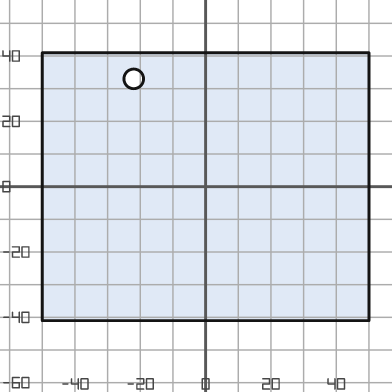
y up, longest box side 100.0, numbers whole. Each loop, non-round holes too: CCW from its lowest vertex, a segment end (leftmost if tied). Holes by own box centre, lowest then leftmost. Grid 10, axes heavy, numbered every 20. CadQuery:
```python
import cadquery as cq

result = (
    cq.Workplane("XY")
    .moveTo(-50.0, -41.0)
    .lineTo(50.0, -41.0)
    .lineTo(50.0, 41.0)
    .lineTo(-50.0, 41.0)
    .close()
    .moveTo(-22.0, 33.0)
    .circle(3.0)
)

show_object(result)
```